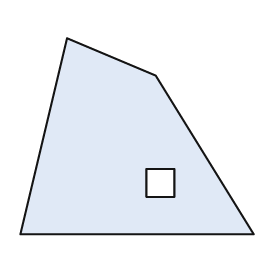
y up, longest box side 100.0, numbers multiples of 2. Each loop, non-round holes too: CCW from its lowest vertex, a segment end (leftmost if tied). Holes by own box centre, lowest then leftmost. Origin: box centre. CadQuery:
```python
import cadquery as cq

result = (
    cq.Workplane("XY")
    .moveTo(-50.0, -42.0)
    .lineTo(50.0, -42.0)
    .lineTo(8.0, 26.0)
    .lineTo(-30.0, 42.0)
    .close()
    .moveTo(4.0, -26.0)
    .lineTo(16.0, -26.0)
    .lineTo(16.0, -14.0)
    .lineTo(4.0, -14.0)
    .close()
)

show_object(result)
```